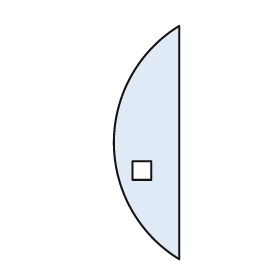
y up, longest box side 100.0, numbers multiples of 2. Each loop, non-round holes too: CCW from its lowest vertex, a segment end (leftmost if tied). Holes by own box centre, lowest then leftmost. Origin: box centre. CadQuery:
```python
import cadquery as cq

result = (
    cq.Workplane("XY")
    .moveTo(14.0, -50.0)
    .lineTo(14.0, 50.0)
    .threePointArc((-14.0, 0.0), (14.0, -50.0))
    .close()
    .moveTo(-6.0, -16.0)
    .lineTo(2.0, -16.0)
    .lineTo(2.0, -8.0)
    .lineTo(-6.0, -8.0)
    .close()
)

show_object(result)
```